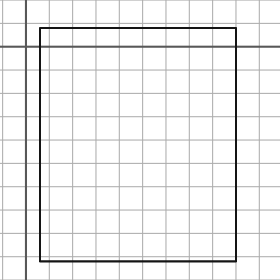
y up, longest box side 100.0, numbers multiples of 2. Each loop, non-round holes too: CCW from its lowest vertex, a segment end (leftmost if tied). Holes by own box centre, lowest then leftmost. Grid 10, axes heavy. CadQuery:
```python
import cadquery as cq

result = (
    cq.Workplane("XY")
    .moveTo(6.0, -92.0)
    .lineTo(90.0, -92.0)
    .lineTo(90.0, 8.0)
    .lineTo(6.0, 8.0)
    .close()
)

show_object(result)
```